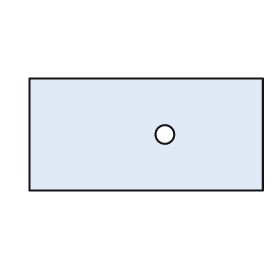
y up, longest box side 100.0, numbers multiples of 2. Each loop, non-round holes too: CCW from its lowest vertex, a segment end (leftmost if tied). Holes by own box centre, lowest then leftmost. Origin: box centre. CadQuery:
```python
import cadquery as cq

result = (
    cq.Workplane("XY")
    .moveTo(-50.0, -24.0)
    .lineTo(50.0, -24.0)
    .lineTo(50.0, 24.0)
    .lineTo(-50.0, 24.0)
    .close()
    .moveTo(8.0, 0.0)
    .circle(4.0)
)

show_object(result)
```